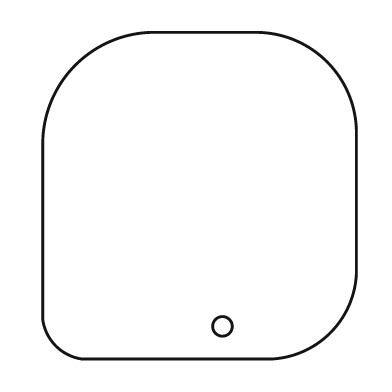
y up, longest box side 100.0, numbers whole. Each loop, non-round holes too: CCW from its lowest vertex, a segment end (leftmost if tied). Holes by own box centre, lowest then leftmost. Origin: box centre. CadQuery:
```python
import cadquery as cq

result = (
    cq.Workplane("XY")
    .moveTo(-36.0, -50.0)
    .lineTo(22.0, -50.0)
    .threePointArc((40.0, -42.0), (48.0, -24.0))
    .lineTo(48.0, 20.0)
    .threePointArc((39.0, 41.0), (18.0, 50.0))
    .lineTo(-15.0, 50.0)
    .threePointArc((-38.0, 40.0), (-48.0, 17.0))
    .lineTo(-48.0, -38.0)
    .threePointArc((-44.0, -46.0), (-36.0, -50.0))
    .close()
    .moveTo(7.0, -40.0)
    .circle(3.0)
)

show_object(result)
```